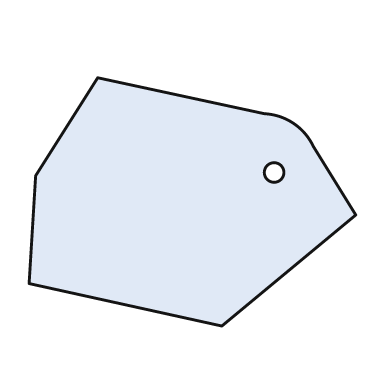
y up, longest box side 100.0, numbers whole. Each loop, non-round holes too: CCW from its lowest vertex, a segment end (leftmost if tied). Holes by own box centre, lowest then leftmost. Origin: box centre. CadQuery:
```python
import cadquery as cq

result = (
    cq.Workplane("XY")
    .moveTo(9.0, -38.0)
    .lineTo(50.0, -4.0)
    .lineTo(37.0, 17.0)
    .threePointArc((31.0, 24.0), (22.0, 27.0))
    .lineTo(-29.0, 38.0)
    .lineTo(-48.0, 8.0)
    .lineTo(-50.0, -25.0)
    .close()
    .moveTo(25.0, 9.0)
    .circle(3.0)
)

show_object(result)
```